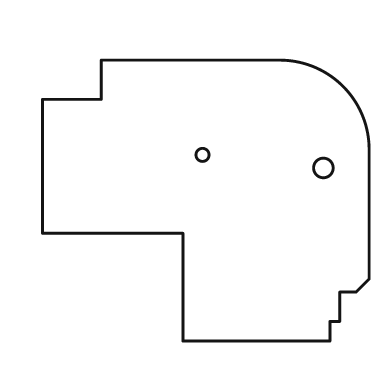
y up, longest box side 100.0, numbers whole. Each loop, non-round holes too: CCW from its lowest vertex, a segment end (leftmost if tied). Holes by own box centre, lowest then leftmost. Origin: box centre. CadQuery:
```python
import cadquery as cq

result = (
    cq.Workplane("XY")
    .moveTo(-7.0, -43.0)
    .lineTo(38.0, -43.0)
    .lineTo(38.0, -37.0)
    .lineTo(41.0, -37.0)
    .lineTo(41.0, -28.0)
    .lineTo(46.0, -28.0)
    .lineTo(50.0, -24.0)
    .lineTo(50.0, 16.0)
    .threePointArc((42.0, 35.0), (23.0, 43.0))
    .lineTo(-32.0, 43.0)
    .lineTo(-32.0, 31.0)
    .lineTo(-50.0, 31.0)
    .lineTo(-50.0, -10.0)
    .lineTo(-7.0, -10.0)
    .close()
    .moveTo(36.0, 10.0)
    .circle(3.0)
    .moveTo(-1.0, 14.0)
    .circle(2.0)
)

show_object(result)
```